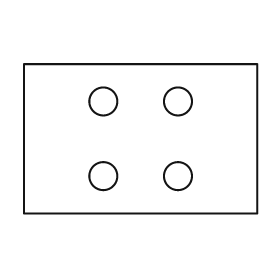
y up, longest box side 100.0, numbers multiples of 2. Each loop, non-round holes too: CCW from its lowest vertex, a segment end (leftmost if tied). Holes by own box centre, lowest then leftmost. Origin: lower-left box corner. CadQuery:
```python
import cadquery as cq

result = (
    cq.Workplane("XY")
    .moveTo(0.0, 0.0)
    .lineTo(100.0, 0.0)
    .lineTo(100.0, 64.0)
    .lineTo(0.0, 64.0)
    .close()
    .moveTo(34.0, 16.0)
    .circle(6.0)
    .moveTo(66.0, 16.0)
    .circle(6.0)
    .moveTo(34.0, 48.0)
    .circle(6.0)
    .moveTo(66.0, 48.0)
    .circle(6.0)
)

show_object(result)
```